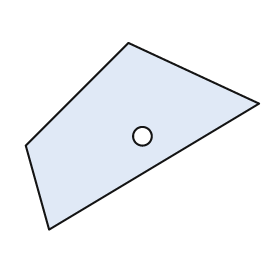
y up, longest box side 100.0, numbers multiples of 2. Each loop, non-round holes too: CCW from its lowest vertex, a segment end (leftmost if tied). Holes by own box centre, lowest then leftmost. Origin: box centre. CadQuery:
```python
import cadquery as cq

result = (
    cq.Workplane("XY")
    .moveTo(-40.0, -40.0)
    .lineTo(50.0, 14.0)
    .lineTo(-6.0, 40.0)
    .lineTo(-50.0, -4.0)
    .close()
    .moveTo(0.0, 0.0)
    .circle(4.0)
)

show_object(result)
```